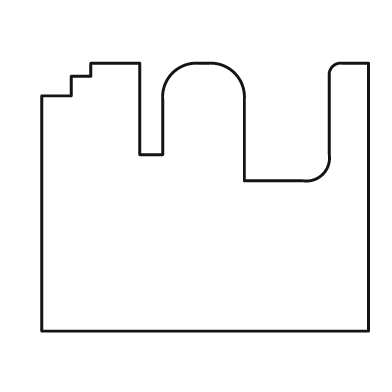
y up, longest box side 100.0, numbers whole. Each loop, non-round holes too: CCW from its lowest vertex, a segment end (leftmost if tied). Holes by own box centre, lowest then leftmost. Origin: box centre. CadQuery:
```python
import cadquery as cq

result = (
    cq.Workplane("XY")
    .moveTo(-50.0, -41.0)
    .lineTo(50.0, -41.0)
    .lineTo(50.0, 41.0)
    .lineTo(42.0, 41.0)
    .threePointArc((39.0, 40.0), (38.0, 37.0))
    .lineTo(38.0, 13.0)
    .threePointArc((36.0, 7.0), (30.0, 5.0))
    .lineTo(12.0, 5.0)
    .lineTo(12.0, 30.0)
    .threePointArc((9.0, 38.0), (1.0, 41.0))
    .lineTo(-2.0, 41.0)
    .threePointArc((-10.0, 38.0), (-13.0, 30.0))
    .lineTo(-13.0, 13.0)
    .lineTo(-20.0, 13.0)
    .lineTo(-20.0, 41.0)
    .lineTo(-35.0, 41.0)
    .lineTo(-35.0, 37.0)
    .lineTo(-41.0, 37.0)
    .lineTo(-41.0, 31.0)
    .lineTo(-50.0, 31.0)
    .close()
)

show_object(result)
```